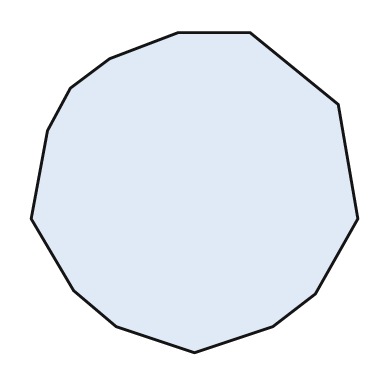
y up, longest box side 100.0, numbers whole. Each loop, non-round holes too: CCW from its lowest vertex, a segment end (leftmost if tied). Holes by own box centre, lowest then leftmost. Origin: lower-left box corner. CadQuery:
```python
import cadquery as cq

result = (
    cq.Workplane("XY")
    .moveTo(50.0, 0.0)
    .lineTo(74.0, 8.0)
    .lineTo(87.0, 18.0)
    .lineTo(100.0, 41.0)
    .lineTo(94.0, 76.0)
    .lineTo(67.0, 98.0)
    .lineTo(45.0, 98.0)
    .lineTo(24.0, 90.0)
    .lineTo(12.0, 81.0)
    .lineTo(5.0, 68.0)
    .lineTo(0.0, 41.0)
    .lineTo(13.0, 19.0)
    .lineTo(26.0, 8.0)
    .close()
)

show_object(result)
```